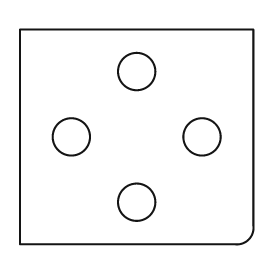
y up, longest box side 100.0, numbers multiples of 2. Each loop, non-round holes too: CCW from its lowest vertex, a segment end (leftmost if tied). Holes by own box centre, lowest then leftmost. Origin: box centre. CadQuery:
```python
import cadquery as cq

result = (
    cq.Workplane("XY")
    .moveTo(-50.0, -46.0)
    .lineTo(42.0, -46.0)
    .threePointArc((48.0, -44.0), (50.0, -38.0))
    .lineTo(50.0, 46.0)
    .lineTo(-50.0, 46.0)
    .close()
    .moveTo(0.0, -28.0)
    .circle(8.0)
    .moveTo(-28.0, 0.0)
    .circle(8.0)
    .moveTo(28.0, 0.0)
    .circle(8.0)
    .moveTo(0.0, 28.0)
    .circle(8.0)
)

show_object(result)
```